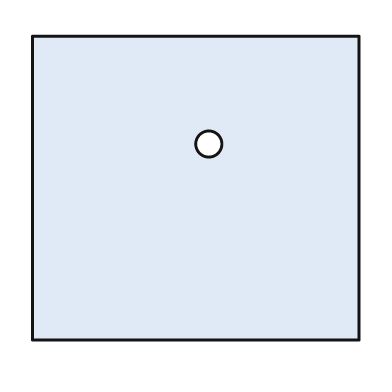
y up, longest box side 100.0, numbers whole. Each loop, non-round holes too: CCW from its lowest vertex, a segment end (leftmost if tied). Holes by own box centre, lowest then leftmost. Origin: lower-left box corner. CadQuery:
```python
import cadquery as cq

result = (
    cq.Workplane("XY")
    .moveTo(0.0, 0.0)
    .lineTo(100.0, 0.0)
    .lineTo(100.0, 93.0)
    .lineTo(0.0, 93.0)
    .close()
    .moveTo(54.0, 60.0)
    .circle(4.0)
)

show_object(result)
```